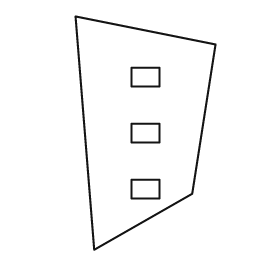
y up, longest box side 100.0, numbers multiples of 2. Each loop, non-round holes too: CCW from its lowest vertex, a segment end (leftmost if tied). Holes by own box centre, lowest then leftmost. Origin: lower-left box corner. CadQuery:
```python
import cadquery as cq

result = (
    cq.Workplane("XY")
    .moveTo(8.0, 0.0)
    .lineTo(50.0, 24.0)
    .lineTo(60.0, 88.0)
    .lineTo(0.0, 100.0)
    .close()
    .moveTo(24.0, 22.0)
    .lineTo(36.0, 22.0)
    .lineTo(36.0, 30.0)
    .lineTo(24.0, 30.0)
    .close()
    .moveTo(24.0, 46.0)
    .lineTo(36.0, 46.0)
    .lineTo(36.0, 54.0)
    .lineTo(24.0, 54.0)
    .close()
    .moveTo(24.0, 70.0)
    .lineTo(36.0, 70.0)
    .lineTo(36.0, 78.0)
    .lineTo(24.0, 78.0)
    .close()
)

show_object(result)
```